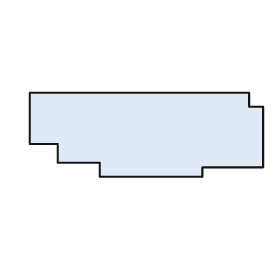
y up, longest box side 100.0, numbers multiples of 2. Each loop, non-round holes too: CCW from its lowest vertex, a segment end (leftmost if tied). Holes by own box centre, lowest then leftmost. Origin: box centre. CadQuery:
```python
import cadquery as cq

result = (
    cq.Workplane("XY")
    .moveTo(-20.0, -18.0)
    .lineTo(24.0, -18.0)
    .lineTo(24.0, -14.0)
    .lineTo(50.0, -14.0)
    .lineTo(50.0, 12.0)
    .lineTo(44.0, 12.0)
    .lineTo(44.0, 18.0)
    .lineTo(-50.0, 18.0)
    .lineTo(-50.0, -4.0)
    .lineTo(-38.0, -4.0)
    .lineTo(-38.0, -12.0)
    .lineTo(-20.0, -12.0)
    .close()
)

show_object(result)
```